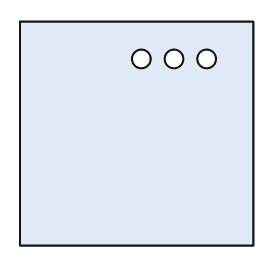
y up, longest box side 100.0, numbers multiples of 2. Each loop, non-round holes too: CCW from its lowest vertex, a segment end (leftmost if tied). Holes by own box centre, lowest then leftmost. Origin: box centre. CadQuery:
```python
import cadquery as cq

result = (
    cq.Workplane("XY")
    .moveTo(-50.0, -48.0)
    .lineTo(50.0, -48.0)
    .lineTo(50.0, 48.0)
    .lineTo(-50.0, 48.0)
    .close()
    .moveTo(2.0, 32.0)
    .circle(4.0)
    .moveTo(16.0, 32.0)
    .circle(4.0)
    .moveTo(30.0, 32.0)
    .circle(4.0)
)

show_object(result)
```